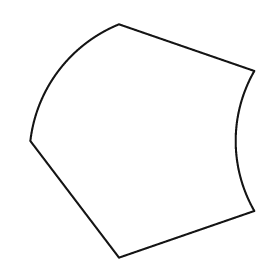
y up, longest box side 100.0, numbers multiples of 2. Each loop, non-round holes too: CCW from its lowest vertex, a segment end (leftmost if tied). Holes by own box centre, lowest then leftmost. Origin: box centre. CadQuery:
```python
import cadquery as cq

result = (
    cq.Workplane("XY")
    .moveTo(-10.0, -50.0)
    .lineTo(48.0, -30.0)
    .threePointArc((40.0, 0.0), (48.0, 30.0))
    .lineTo(-10.0, 50.0)
    .threePointArc((-36.0, 30.0), (-48.0, 0.0))
    .close()
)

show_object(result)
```